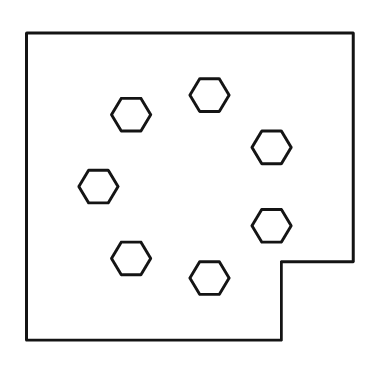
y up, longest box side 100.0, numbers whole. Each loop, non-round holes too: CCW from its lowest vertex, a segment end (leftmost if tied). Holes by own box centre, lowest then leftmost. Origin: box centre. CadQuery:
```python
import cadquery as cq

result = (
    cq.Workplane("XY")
    .moveTo(-50.0, -47.0)
    .lineTo(28.0, -47.0)
    .lineTo(28.0, -23.0)
    .lineTo(50.0, -23.0)
    .lineTo(50.0, 47.0)
    .lineTo(-50.0, 47.0)
    .close()
    .moveTo(3.0, -33.0)
    .lineTo(9.0, -33.0)
    .lineTo(12.0, -28.0)
    .lineTo(9.0, -23.0)
    .lineTo(3.0, -23.0)
    .lineTo(0.0, -28.0)
    .close()
    .moveTo(-21.0, -27.0)
    .lineTo(-15.0, -27.0)
    .lineTo(-12.0, -22.0)
    .lineTo(-15.0, -17.0)
    .lineTo(-21.0, -17.0)
    .lineTo(-24.0, -22.0)
    .close()
    .moveTo(22.0, -17.0)
    .lineTo(28.0, -17.0)
    .lineTo(31.0, -12.0)
    .lineTo(28.0, -7.0)
    .lineTo(22.0, -7.0)
    .lineTo(19.0, -12.0)
    .close()
    .moveTo(-31.0, -5.0)
    .lineTo(-25.0, -5.0)
    .lineTo(-22.0, 0.0)
    .lineTo(-25.0, 5.0)
    .lineTo(-31.0, 5.0)
    .lineTo(-34.0, 0.0)
    .close()
    .moveTo(22.0, 7.0)
    .lineTo(28.0, 7.0)
    .lineTo(31.0, 12.0)
    .lineTo(28.0, 17.0)
    .lineTo(22.0, 17.0)
    .lineTo(19.0, 12.0)
    .close()
    .moveTo(-21.0, 17.0)
    .lineTo(-15.0, 17.0)
    .lineTo(-12.0, 22.0)
    .lineTo(-15.0, 27.0)
    .lineTo(-21.0, 27.0)
    .lineTo(-24.0, 22.0)
    .close()
    .moveTo(3.0, 23.0)
    .lineTo(9.0, 23.0)
    .lineTo(12.0, 28.0)
    .lineTo(9.0, 33.0)
    .lineTo(3.0, 33.0)
    .lineTo(0.0, 28.0)
    .close()
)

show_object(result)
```